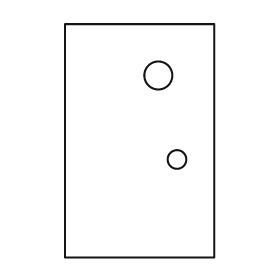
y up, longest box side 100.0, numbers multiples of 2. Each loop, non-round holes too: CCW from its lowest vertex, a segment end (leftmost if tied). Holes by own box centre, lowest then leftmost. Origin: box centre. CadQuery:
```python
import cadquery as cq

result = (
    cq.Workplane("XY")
    .moveTo(-32.0, -50.0)
    .lineTo(32.0, -50.0)
    .lineTo(32.0, 50.0)
    .lineTo(-32.0, 50.0)
    .close()
    .moveTo(16.0, -8.0)
    .circle(4.0)
    .moveTo(8.0, 28.0)
    .circle(6.0)
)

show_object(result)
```